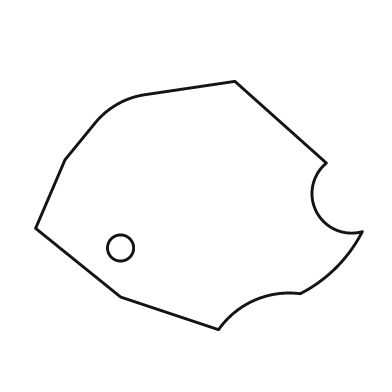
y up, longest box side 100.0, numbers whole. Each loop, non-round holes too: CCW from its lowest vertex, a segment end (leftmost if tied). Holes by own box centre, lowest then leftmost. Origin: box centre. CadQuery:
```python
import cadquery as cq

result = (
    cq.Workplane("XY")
    .moveTo(6.0, -38.0)
    .threePointArc((17.0, -29.0), (31.0, -27.0))
    .threePointArc((42.0, -19.0), (50.0, -8.0))
    .threePointArc((36.0, -2.0), (39.0, 13.0))
    .lineTo(11.0, 38.0)
    .lineTo(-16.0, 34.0)
    .threePointArc((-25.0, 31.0), (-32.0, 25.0))
    .lineTo(-41.0, 14.0)
    .lineTo(-50.0, -7.0)
    .lineTo(-24.0, -28.0)
    .close()
    .moveTo(-24.0, -13.0)
    .circle(4.0)
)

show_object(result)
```